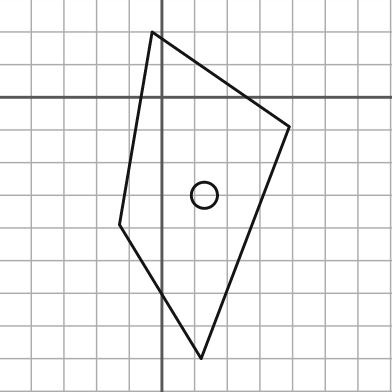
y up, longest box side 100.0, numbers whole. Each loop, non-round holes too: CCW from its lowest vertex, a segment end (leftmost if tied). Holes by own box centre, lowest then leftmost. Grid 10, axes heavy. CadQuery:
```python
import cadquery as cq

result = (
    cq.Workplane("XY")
    .moveTo(12.0, -80.0)
    .lineTo(39.0, -9.0)
    .lineTo(-3.0, 20.0)
    .lineTo(-13.0, -39.0)
    .close()
    .moveTo(13.0, -30.0)
    .circle(4.0)
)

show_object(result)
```